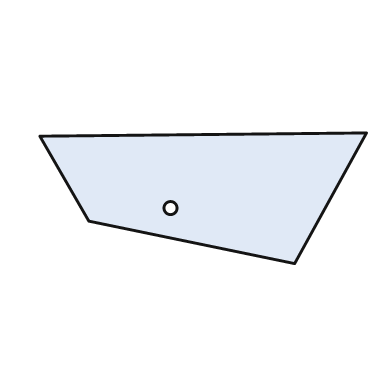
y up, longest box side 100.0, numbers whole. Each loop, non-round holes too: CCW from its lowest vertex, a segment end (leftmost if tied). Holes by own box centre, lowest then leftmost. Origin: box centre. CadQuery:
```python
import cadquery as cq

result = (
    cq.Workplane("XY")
    .moveTo(28.0, -20.0)
    .lineTo(50.0, 20.0)
    .lineTo(-50.0, 19.0)
    .lineTo(-35.0, -7.0)
    .close()
    .moveTo(-10.0, -3.0)
    .circle(2.0)
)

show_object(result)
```